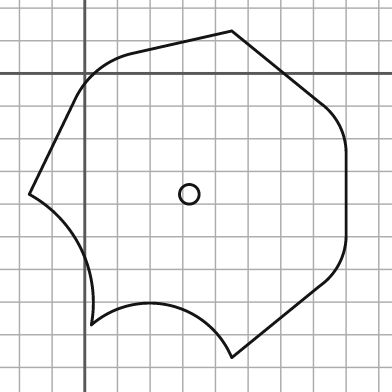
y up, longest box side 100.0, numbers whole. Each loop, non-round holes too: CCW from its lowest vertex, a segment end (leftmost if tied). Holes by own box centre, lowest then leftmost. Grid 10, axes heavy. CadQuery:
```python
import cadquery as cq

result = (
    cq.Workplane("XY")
    .moveTo(45.0, -87.0)
    .lineTo(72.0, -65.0)
    .threePointArc((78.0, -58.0), (80.0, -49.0))
    .lineTo(80.0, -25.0)
    .threePointArc((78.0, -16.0), (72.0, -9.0))
    .lineTo(45.0, 13.0)
    .lineTo(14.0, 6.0)
    .threePointArc((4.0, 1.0), (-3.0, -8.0))
    .lineTo(-17.0, -37.0)
    .threePointArc((-1.0, -54.0), (2.0, -77.0))
    .threePointArc((26.0, -71.0), (45.0, -87.0))
    .close()
    .moveTo(32.0, -37.0)
    .circle(3.0)
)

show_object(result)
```